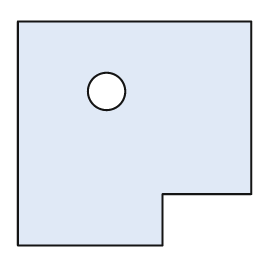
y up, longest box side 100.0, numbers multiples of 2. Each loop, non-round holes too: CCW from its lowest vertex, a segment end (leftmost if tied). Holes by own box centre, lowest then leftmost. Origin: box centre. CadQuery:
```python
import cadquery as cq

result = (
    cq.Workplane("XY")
    .moveTo(-50.0, -48.0)
    .lineTo(12.0, -48.0)
    .lineTo(12.0, -26.0)
    .lineTo(50.0, -26.0)
    .lineTo(50.0, 48.0)
    .lineTo(-50.0, 48.0)
    .close()
    .moveTo(-12.0, 18.0)
    .circle(8.0)
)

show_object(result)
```